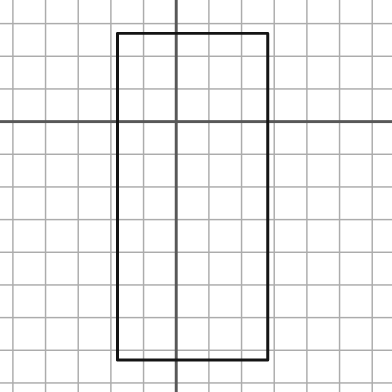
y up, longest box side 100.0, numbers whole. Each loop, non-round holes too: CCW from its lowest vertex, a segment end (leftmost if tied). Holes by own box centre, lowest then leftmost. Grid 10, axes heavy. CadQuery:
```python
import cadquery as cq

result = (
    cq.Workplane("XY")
    .moveTo(-18.0, -73.0)
    .lineTo(28.0, -73.0)
    .lineTo(28.0, 27.0)
    .lineTo(-18.0, 27.0)
    .close()
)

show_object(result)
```